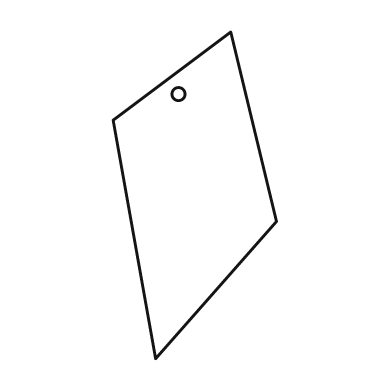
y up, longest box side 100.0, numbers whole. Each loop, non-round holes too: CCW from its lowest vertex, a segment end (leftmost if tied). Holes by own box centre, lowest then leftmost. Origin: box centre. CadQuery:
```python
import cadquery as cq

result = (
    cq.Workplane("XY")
    .moveTo(-12.0, -50.0)
    .lineTo(25.0, -8.0)
    .lineTo(11.0, 50.0)
    .lineTo(-25.0, 23.0)
    .close()
    .moveTo(-5.0, 31.0)
    .circle(2.0)
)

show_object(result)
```